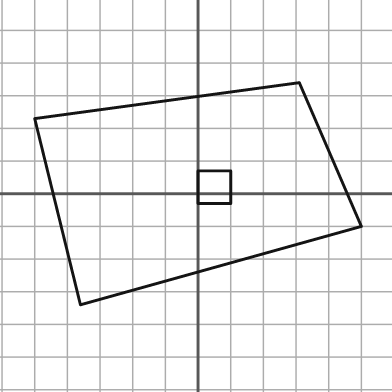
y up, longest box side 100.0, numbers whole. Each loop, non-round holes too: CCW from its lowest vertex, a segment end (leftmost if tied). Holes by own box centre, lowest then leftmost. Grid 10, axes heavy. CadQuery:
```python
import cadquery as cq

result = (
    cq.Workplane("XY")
    .moveTo(-36.0, -34.0)
    .lineTo(50.0, -10.0)
    .lineTo(31.0, 34.0)
    .lineTo(-50.0, 23.0)
    .close()
    .moveTo(0.0, -3.0)
    .lineTo(10.0, -3.0)
    .lineTo(10.0, 7.0)
    .lineTo(0.0, 7.0)
    .close()
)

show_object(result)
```